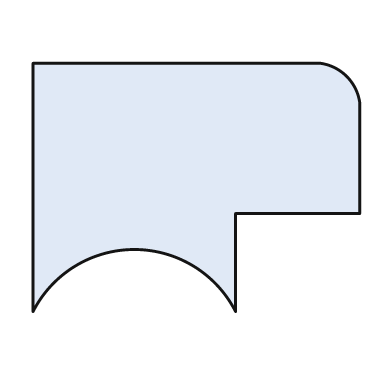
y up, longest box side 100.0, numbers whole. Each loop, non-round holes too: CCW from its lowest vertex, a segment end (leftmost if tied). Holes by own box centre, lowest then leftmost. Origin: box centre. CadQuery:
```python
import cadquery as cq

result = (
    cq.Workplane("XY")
    .moveTo(-50.0, -38.0)
    .threePointArc((-19.0, -19.0), (12.0, -38.0))
    .lineTo(12.0, -8.0)
    .lineTo(50.0, -8.0)
    .lineTo(50.0, 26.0)
    .threePointArc((46.0, 34.0), (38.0, 38.0))
    .lineTo(-50.0, 38.0)
    .close()
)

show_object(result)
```